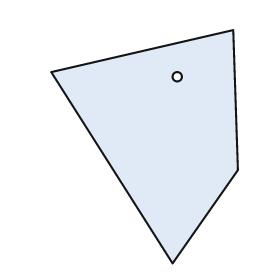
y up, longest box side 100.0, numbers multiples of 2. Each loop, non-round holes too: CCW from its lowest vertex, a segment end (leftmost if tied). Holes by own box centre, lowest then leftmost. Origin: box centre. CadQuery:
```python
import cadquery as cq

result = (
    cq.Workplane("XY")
    .moveTo(12.0, -50.0)
    .lineTo(40.0, -10.0)
    .lineTo(38.0, 50.0)
    .lineTo(-40.0, 32.0)
    .close()
    .moveTo(14.0, 30.0)
    .circle(2.0)
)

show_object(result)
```